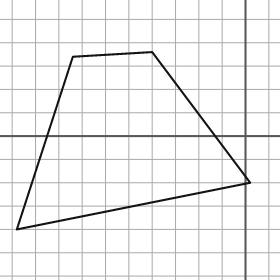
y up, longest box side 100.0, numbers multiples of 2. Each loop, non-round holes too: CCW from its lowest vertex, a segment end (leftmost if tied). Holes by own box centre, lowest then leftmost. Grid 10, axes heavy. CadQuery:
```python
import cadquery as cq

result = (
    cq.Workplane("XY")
    .moveTo(-98.0, -40.0)
    .lineTo(2.0, -20.0)
    .lineTo(-40.0, 36.0)
    .lineTo(-74.0, 34.0)
    .close()
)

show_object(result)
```